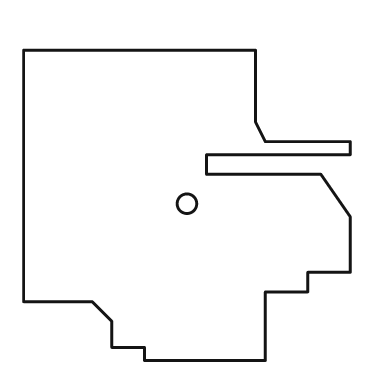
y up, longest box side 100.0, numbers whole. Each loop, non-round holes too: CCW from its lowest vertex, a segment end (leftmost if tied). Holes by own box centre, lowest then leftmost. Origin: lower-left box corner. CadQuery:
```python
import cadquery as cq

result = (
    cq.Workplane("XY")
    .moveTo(37.0, 0.0)
    .lineTo(74.0, 0.0)
    .lineTo(74.0, 21.0)
    .lineTo(87.0, 21.0)
    .lineTo(87.0, 27.0)
    .lineTo(100.0, 27.0)
    .lineTo(100.0, 44.0)
    .lineTo(91.0, 57.0)
    .lineTo(56.0, 57.0)
    .lineTo(56.0, 63.0)
    .lineTo(100.0, 63.0)
    .lineTo(100.0, 67.0)
    .lineTo(74.0, 67.0)
    .lineTo(71.0, 73.0)
    .lineTo(71.0, 95.0)
    .lineTo(0.0, 95.0)
    .lineTo(0.0, 18.0)
    .lineTo(21.0, 18.0)
    .lineTo(27.0, 12.0)
    .lineTo(27.0, 4.0)
    .lineTo(37.0, 4.0)
    .close()
    .moveTo(50.0, 48.0)
    .circle(3.0)
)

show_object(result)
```